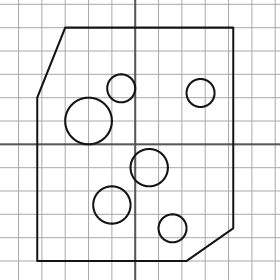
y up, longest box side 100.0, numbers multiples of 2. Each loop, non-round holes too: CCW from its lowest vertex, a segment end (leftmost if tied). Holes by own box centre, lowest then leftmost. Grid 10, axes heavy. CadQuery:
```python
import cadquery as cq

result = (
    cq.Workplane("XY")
    .moveTo(-42.0, -50.0)
    .lineTo(22.0, -50.0)
    .lineTo(42.0, -36.0)
    .lineTo(42.0, 50.0)
    .lineTo(-30.0, 50.0)
    .lineTo(-42.0, 20.0)
    .close()
    .moveTo(16.0, -36.0)
    .circle(6.0)
    .moveTo(-10.0, -26.0)
    .circle(8.0)
    .moveTo(6.0, -10.0)
    .circle(8.0)
    .moveTo(-20.0, 10.0)
    .circle(10.0)
    .moveTo(28.0, 22.0)
    .circle(6.0)
    .moveTo(-6.0, 24.0)
    .circle(6.0)
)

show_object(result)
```